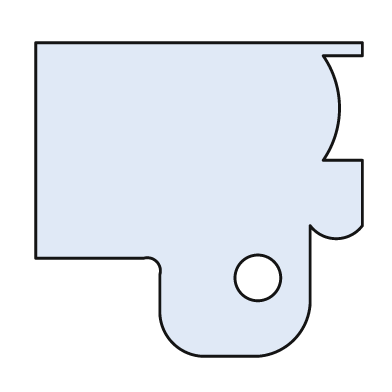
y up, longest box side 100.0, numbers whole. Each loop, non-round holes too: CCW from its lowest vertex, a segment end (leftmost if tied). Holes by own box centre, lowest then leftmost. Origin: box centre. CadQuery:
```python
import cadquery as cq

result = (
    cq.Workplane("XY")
    .moveTo(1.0, -48.0)
    .lineTo(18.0, -48.0)
    .threePointArc((29.0, -43.0), (34.0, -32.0))
    .lineTo(34.0, -8.0)
    .threePointArc((42.0, -12.0), (50.0, -8.0))
    .lineTo(50.0, 12.0)
    .lineTo(38.0, 12.0)
    .threePointArc((43.0, 28.0), (38.0, 44.0))
    .lineTo(50.0, 44.0)
    .lineTo(50.0, 48.0)
    .lineTo(-50.0, 48.0)
    .lineTo(-50.0, -18.0)
    .lineTo(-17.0, -18.0)
    .threePointArc((-13.0, -19.0), (-12.0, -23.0))
    .lineTo(-12.0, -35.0)
    .threePointArc((-8.0, -44.0), (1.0, -48.0))
    .close()
    .moveTo(18.0, -24.0)
    .circle(7.0)
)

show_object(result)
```